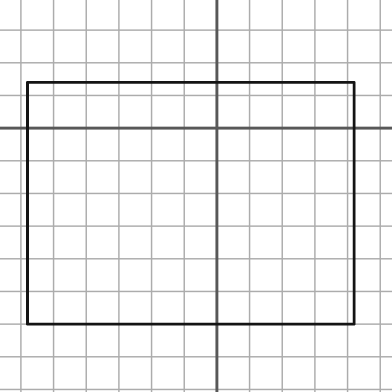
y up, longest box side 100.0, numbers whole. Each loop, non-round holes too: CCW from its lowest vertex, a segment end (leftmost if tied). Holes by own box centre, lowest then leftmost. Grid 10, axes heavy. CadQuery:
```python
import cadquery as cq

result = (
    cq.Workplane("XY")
    .moveTo(-58.0, -60.0)
    .lineTo(42.0, -60.0)
    .lineTo(42.0, 14.0)
    .lineTo(-58.0, 14.0)
    .close()
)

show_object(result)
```